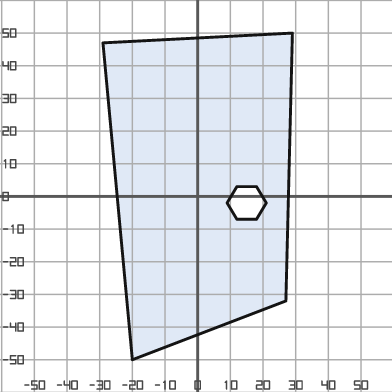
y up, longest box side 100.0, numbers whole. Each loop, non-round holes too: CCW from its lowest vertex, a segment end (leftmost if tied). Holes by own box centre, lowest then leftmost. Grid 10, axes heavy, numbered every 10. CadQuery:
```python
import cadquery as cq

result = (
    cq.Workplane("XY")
    .moveTo(-20.0, -50.0)
    .lineTo(27.0, -32.0)
    .lineTo(29.0, 50.0)
    .lineTo(-29.0, 47.0)
    .close()
    .moveTo(12.0, -7.0)
    .lineTo(18.0, -7.0)
    .lineTo(21.0, -2.0)
    .lineTo(18.0, 3.0)
    .lineTo(12.0, 3.0)
    .lineTo(9.0, -2.0)
    .close()
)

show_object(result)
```